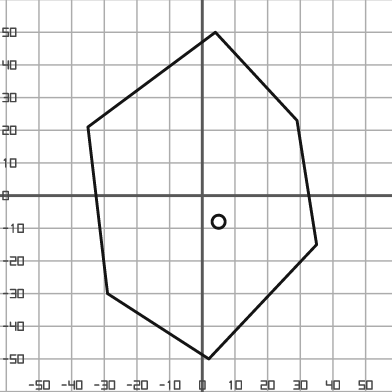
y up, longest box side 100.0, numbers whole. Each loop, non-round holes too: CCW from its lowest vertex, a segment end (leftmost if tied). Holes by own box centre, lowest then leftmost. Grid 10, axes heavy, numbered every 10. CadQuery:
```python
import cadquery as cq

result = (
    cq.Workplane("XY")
    .moveTo(2.0, -50.0)
    .lineTo(35.0, -15.0)
    .lineTo(29.0, 23.0)
    .lineTo(4.0, 50.0)
    .lineTo(-35.0, 21.0)
    .lineTo(-29.0, -30.0)
    .close()
    .moveTo(5.0, -8.0)
    .circle(2.0)
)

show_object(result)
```